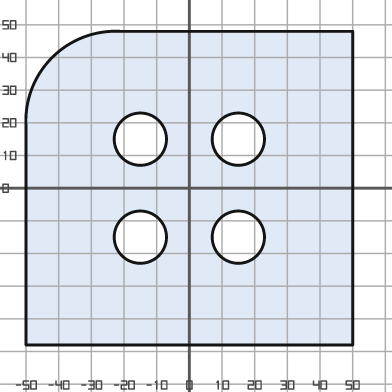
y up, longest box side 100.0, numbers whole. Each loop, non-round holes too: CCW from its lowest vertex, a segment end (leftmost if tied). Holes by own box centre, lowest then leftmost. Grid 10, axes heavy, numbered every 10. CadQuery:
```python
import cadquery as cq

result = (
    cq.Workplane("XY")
    .moveTo(-50.0, -48.0)
    .lineTo(50.0, -48.0)
    .lineTo(50.0, 48.0)
    .lineTo(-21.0, 48.0)
    .threePointArc((-42.0, 40.0), (-50.0, 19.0))
    .close()
    .moveTo(-15.0, -15.0)
    .circle(8.0)
    .moveTo(15.0, -15.0)
    .circle(8.0)
    .moveTo(-15.0, 15.0)
    .circle(8.0)
    .moveTo(15.0, 15.0)
    .circle(8.0)
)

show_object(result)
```